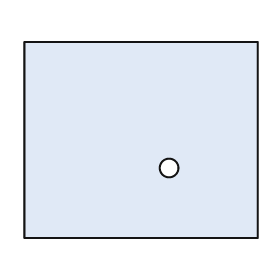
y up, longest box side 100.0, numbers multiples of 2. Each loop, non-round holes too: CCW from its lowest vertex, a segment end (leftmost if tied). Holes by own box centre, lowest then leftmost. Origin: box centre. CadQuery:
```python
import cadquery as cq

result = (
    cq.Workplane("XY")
    .moveTo(-50.0, -42.0)
    .lineTo(50.0, -42.0)
    .lineTo(50.0, 42.0)
    .lineTo(-50.0, 42.0)
    .close()
    .moveTo(12.0, -12.0)
    .circle(4.0)
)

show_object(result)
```